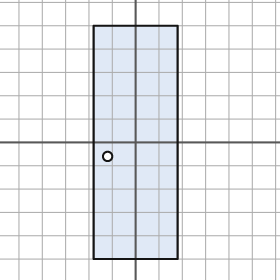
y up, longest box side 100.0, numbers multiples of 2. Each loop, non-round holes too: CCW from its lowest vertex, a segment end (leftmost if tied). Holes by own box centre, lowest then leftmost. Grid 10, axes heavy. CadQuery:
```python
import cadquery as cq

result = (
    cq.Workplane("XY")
    .moveTo(-18.0, -50.0)
    .lineTo(18.0, -50.0)
    .lineTo(18.0, 50.0)
    .lineTo(-18.0, 50.0)
    .close()
    .moveTo(-12.0, -6.0)
    .circle(2.0)
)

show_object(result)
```